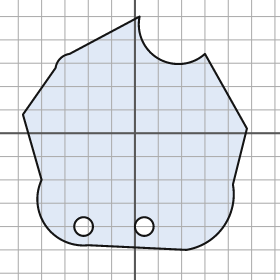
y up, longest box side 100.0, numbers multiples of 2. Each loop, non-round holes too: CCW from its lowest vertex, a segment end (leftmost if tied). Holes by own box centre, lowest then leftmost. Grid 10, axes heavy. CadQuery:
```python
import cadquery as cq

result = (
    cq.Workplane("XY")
    .moveTo(22.0, -50.0)
    .threePointArc((38.0, -40.0), (42.0, -22.0))
    .lineTo(48.0, 2.0)
    .lineTo(30.0, 34.0)
    .threePointArc((10.0, 32.0), (2.0, 50.0))
    .lineTo(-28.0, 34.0)
    .threePointArc((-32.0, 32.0), (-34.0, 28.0))
    .lineTo(-48.0, 8.0)
    .lineTo(-40.0, -20.0)
    .threePointArc((-38.0, -40.0), (-20.0, -48.0))
    .close()
    .moveTo(-22.0, -40.0)
    .circle(4.0)
    .moveTo(4.0, -40.0)
    .circle(4.0)
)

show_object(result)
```